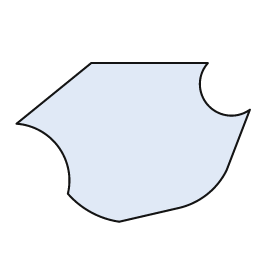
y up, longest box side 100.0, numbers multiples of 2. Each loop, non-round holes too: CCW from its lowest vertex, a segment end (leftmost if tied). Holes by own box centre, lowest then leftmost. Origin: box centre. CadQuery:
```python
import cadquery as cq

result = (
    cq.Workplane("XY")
    .moveTo(-6.0, -34.0)
    .lineTo(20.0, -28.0)
    .threePointArc((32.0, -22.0), (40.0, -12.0))
    .lineTo(50.0, 14.0)
    .threePointArc((32.0, 16.0), (32.0, 34.0))
    .lineTo(-18.0, 34.0)
    .lineTo(-50.0, 8.0)
    .threePointArc((-32.0, -2.0), (-28.0, -22.0))
    .threePointArc((-18.0, -30.0), (-6.0, -34.0))
    .close()
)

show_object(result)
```